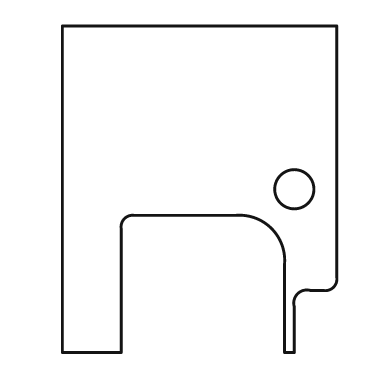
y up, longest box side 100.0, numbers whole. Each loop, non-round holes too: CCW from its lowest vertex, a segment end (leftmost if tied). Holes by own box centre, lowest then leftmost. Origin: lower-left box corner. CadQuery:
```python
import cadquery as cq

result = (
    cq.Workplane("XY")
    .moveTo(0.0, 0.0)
    .lineTo(18.0, 0.0)
    .lineTo(18.0, 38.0)
    .threePointArc((19.0, 41.0), (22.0, 42.0))
    .lineTo(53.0, 42.0)
    .threePointArc((64.0, 38.0), (68.0, 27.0))
    .lineTo(68.0, 0.0)
    .lineTo(71.0, 0.0)
    .lineTo(71.0, 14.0)
    .threePointArc((72.0, 18.0), (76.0, 19.0))
    .lineTo(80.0, 19.0)
    .threePointArc((83.0, 20.0), (84.0, 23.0))
    .lineTo(84.0, 100.0)
    .lineTo(0.0, 100.0)
    .close()
    .moveTo(71.0, 50.0)
    .circle(6.0)
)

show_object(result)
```